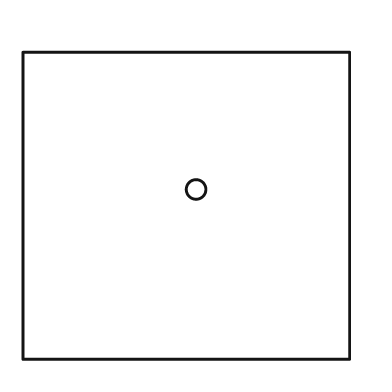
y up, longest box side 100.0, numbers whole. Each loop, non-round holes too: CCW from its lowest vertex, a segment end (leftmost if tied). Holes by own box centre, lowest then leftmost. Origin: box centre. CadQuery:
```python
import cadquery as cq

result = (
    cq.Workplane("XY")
    .moveTo(-50.0, -47.0)
    .lineTo(50.0, -47.0)
    .lineTo(50.0, 47.0)
    .lineTo(-50.0, 47.0)
    .close()
    .moveTo(3.0, 5.0)
    .circle(3.0)
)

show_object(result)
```